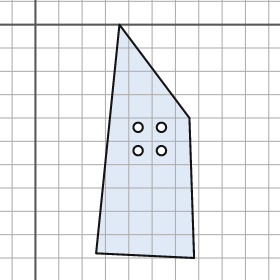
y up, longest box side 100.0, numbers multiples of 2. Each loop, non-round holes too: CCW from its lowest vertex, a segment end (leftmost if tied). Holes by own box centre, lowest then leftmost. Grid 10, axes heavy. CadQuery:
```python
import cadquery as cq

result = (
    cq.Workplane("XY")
    .moveTo(68.0, -100.0)
    .lineTo(66.0, -40.0)
    .lineTo(36.0, 0.0)
    .lineTo(26.0, -98.0)
    .close()
    .moveTo(44.0, -54.0)
    .circle(2.0)
    .moveTo(54.0, -54.0)
    .circle(2.0)
    .moveTo(44.0, -44.0)
    .circle(2.0)
    .moveTo(54.0, -44.0)
    .circle(2.0)
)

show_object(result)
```